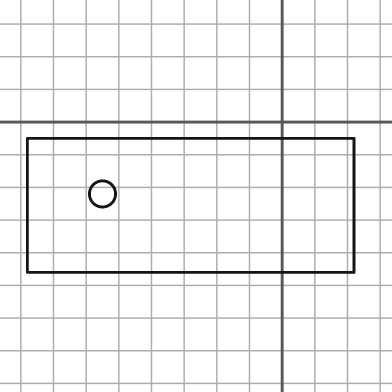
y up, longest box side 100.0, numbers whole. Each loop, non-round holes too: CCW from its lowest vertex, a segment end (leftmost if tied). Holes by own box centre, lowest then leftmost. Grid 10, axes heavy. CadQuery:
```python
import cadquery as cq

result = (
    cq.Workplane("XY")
    .moveTo(-78.0, -46.0)
    .lineTo(22.0, -46.0)
    .lineTo(22.0, -5.0)
    .lineTo(-78.0, -5.0)
    .close()
    .moveTo(-55.0, -22.0)
    .circle(4.0)
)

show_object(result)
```